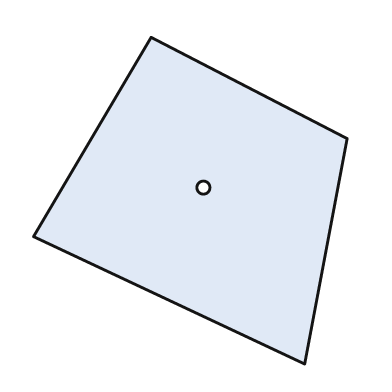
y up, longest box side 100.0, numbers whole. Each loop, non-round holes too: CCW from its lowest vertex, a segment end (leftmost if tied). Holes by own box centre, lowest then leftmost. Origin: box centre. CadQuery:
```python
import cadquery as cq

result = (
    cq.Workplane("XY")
    .moveTo(35.0, -50.0)
    .lineTo(48.0, 19.0)
    .lineTo(-12.0, 50.0)
    .lineTo(-48.0, -11.0)
    .close()
    .moveTo(4.0, 4.0)
    .circle(2.0)
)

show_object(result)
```